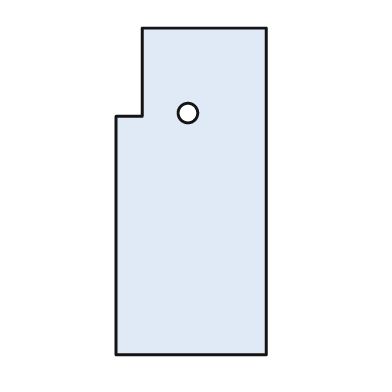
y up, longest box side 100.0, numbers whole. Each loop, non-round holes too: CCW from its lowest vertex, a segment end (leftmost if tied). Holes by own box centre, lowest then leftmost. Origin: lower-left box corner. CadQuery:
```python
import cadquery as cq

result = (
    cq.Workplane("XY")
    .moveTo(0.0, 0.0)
    .lineTo(46.0, 0.0)
    .lineTo(46.0, 100.0)
    .lineTo(8.0, 100.0)
    .lineTo(8.0, 73.0)
    .lineTo(0.0, 73.0)
    .close()
    .moveTo(22.0, 74.0)
    .circle(3.0)
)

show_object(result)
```